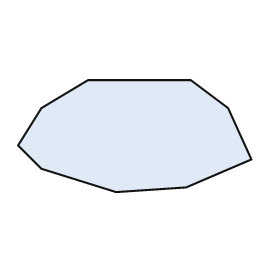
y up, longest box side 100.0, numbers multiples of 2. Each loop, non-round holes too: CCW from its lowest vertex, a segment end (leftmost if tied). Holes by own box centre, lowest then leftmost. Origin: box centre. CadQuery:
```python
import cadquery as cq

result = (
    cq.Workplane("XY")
    .moveTo(-8.0, -24.0)
    .lineTo(22.0, -22.0)
    .lineTo(50.0, -10.0)
    .lineTo(40.0, 12.0)
    .lineTo(24.0, 24.0)
    .lineTo(-20.0, 24.0)
    .lineTo(-40.0, 12.0)
    .lineTo(-50.0, -4.0)
    .lineTo(-40.0, -14.0)
    .close()
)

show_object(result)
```